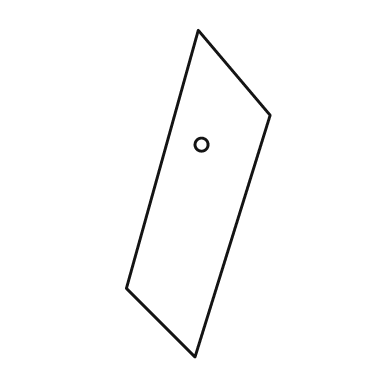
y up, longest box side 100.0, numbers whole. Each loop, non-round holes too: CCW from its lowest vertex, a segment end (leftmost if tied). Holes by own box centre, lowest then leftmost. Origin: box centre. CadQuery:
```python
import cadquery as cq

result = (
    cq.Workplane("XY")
    .moveTo(-1.0, -50.0)
    .lineTo(22.0, 24.0)
    .lineTo(0.0, 50.0)
    .lineTo(-22.0, -29.0)
    .close()
    .moveTo(1.0, 15.0)
    .circle(2.0)
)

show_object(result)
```